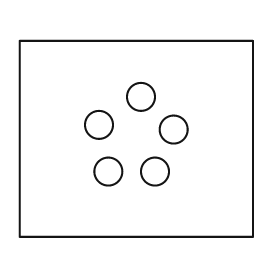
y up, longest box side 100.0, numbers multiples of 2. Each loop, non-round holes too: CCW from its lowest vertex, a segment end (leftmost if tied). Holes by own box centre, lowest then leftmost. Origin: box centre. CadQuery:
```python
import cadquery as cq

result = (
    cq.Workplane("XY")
    .moveTo(-50.0, -42.0)
    .lineTo(50.0, -42.0)
    .lineTo(50.0, 42.0)
    .lineTo(-50.0, 42.0)
    .close()
    .moveTo(-12.0, -14.0)
    .circle(6.0)
    .moveTo(8.0, -14.0)
    .circle(6.0)
    .moveTo(16.0, 4.0)
    .circle(6.0)
    .moveTo(-16.0, 6.0)
    .circle(6.0)
    .moveTo(2.0, 18.0)
    .circle(6.0)
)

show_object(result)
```